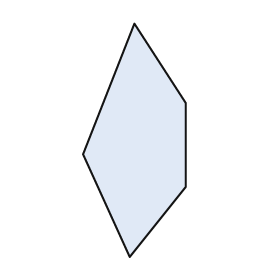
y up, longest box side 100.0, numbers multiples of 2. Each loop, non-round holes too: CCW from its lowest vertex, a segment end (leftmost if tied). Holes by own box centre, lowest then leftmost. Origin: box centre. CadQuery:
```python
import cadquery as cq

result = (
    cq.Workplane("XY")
    .moveTo(-2.0, -50.0)
    .lineTo(22.0, -20.0)
    .lineTo(22.0, 16.0)
    .lineTo(0.0, 50.0)
    .lineTo(-22.0, -6.0)
    .close()
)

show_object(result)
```